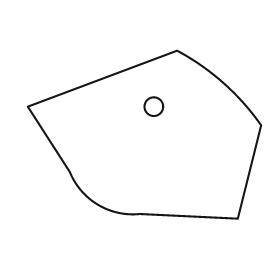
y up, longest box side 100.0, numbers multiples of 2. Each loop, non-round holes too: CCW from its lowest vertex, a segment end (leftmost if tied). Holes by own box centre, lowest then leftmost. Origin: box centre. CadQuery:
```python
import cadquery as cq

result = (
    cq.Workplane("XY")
    .moveTo(40.0, -36.0)
    .lineTo(50.0, 4.0)
    .threePointArc((34.0, 22.0), (14.0, 36.0))
    .lineTo(-50.0, 12.0)
    .lineTo(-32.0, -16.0)
    .threePointArc((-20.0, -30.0), (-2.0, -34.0))
    .close()
    .moveTo(4.0, 12.0)
    .circle(4.0)
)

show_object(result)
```